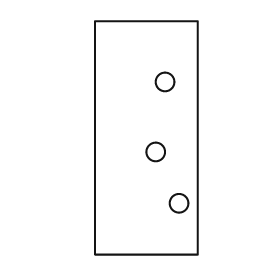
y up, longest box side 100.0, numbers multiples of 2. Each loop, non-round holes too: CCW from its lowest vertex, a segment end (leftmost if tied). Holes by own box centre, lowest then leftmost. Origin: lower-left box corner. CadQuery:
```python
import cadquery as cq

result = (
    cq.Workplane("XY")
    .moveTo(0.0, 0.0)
    .lineTo(44.0, 0.0)
    .lineTo(44.0, 100.0)
    .lineTo(0.0, 100.0)
    .close()
    .moveTo(36.0, 22.0)
    .circle(4.0)
    .moveTo(26.0, 44.0)
    .circle(4.0)
    .moveTo(30.0, 74.0)
    .circle(4.0)
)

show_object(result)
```